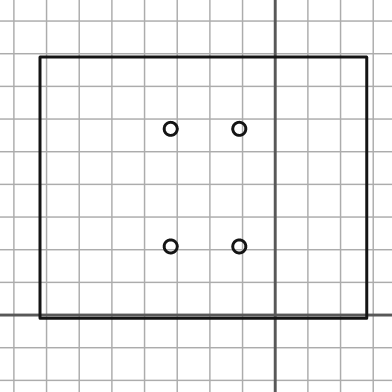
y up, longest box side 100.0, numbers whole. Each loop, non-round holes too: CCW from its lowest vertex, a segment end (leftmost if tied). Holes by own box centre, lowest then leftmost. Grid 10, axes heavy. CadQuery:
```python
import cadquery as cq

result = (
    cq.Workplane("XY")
    .moveTo(-72.0, -1.0)
    .lineTo(28.0, -1.0)
    .lineTo(28.0, 79.0)
    .lineTo(-72.0, 79.0)
    .close()
    .moveTo(-32.0, 21.0)
    .circle(2.0)
    .moveTo(-11.0, 21.0)
    .circle(2.0)
    .moveTo(-32.0, 57.0)
    .circle(2.0)
    .moveTo(-11.0, 57.0)
    .circle(2.0)
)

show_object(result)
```